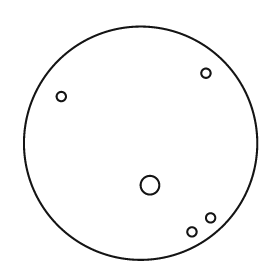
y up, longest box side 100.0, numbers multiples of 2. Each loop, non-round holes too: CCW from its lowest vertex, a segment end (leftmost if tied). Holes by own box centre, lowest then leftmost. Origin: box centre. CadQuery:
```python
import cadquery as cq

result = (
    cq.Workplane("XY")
    .moveTo(0.0, 0.0)
    .circle(50.0)
    .moveTo(22.0, -38.0)
    .circle(2.0)
    .moveTo(30.0, -32.0)
    .circle(2.0)
    .moveTo(4.0, -18.0)
    .circle(4.0)
    .moveTo(-34.0, 20.0)
    .circle(2.0)
    .moveTo(28.0, 30.0)
    .circle(2.0)
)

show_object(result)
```